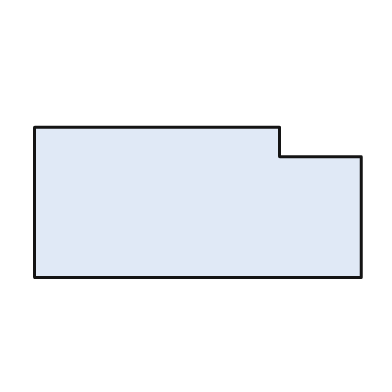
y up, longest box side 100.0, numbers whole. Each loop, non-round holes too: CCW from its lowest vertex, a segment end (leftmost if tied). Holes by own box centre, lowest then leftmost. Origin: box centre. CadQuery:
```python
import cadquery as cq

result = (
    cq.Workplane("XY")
    .moveTo(-50.0, -23.0)
    .lineTo(50.0, -23.0)
    .lineTo(50.0, 14.0)
    .lineTo(25.0, 14.0)
    .lineTo(25.0, 23.0)
    .lineTo(-50.0, 23.0)
    .close()
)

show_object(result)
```